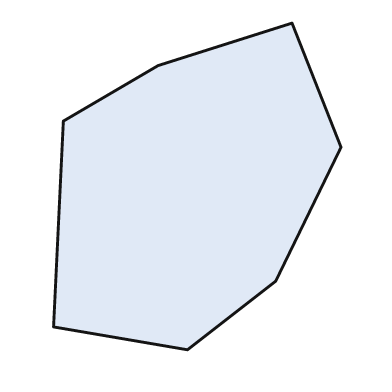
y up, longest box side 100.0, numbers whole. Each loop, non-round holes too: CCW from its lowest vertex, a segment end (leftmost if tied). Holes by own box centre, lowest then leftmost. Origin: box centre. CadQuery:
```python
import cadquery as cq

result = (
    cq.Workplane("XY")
    .moveTo(-3.0, -50.0)
    .lineTo(24.0, -29.0)
    .lineTo(44.0, 12.0)
    .lineTo(29.0, 50.0)
    .lineTo(-12.0, 37.0)
    .lineTo(-41.0, 20.0)
    .lineTo(-44.0, -43.0)
    .close()
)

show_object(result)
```